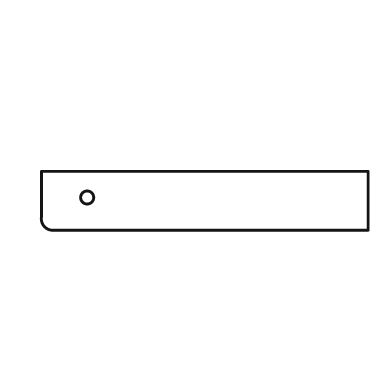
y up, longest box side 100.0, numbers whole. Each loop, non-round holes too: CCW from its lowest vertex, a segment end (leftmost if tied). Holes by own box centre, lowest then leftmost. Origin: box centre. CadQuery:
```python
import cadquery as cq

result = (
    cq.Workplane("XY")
    .moveTo(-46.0, -9.0)
    .lineTo(50.0, -9.0)
    .lineTo(50.0, 9.0)
    .lineTo(-50.0, 9.0)
    .lineTo(-50.0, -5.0)
    .threePointArc((-49.0, -8.0), (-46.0, -9.0))
    .close()
    .moveTo(-36.0, 1.0)
    .circle(2.0)
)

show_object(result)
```